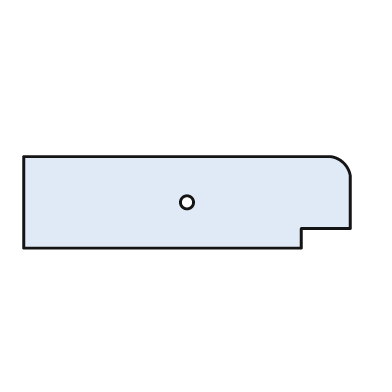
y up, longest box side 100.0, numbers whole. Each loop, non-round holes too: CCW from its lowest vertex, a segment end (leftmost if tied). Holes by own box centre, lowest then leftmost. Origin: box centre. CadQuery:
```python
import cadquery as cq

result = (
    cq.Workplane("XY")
    .moveTo(-50.0, -14.0)
    .lineTo(35.0, -14.0)
    .lineTo(35.0, -8.0)
    .lineTo(50.0, -8.0)
    .lineTo(50.0, 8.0)
    .threePointArc((48.0, 12.0), (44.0, 14.0))
    .lineTo(-50.0, 14.0)
    .close()
    .moveTo(0.0, 0.0)
    .circle(2.0)
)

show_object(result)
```